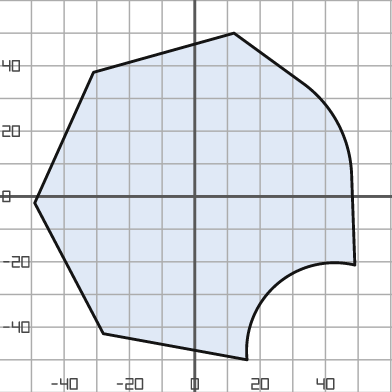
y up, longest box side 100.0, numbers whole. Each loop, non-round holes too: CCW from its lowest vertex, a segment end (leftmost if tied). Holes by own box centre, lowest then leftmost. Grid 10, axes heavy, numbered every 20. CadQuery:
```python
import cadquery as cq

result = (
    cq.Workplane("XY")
    .moveTo(16.0, -50.0)
    .threePointArc((25.0, -27.0), (49.0, -21.0))
    .lineTo(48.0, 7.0)
    .threePointArc((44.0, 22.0), (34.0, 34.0))
    .lineTo(12.0, 50.0)
    .lineTo(-31.0, 38.0)
    .lineTo(-49.0, -2.0)
    .lineTo(-28.0, -42.0)
    .close()
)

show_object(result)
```